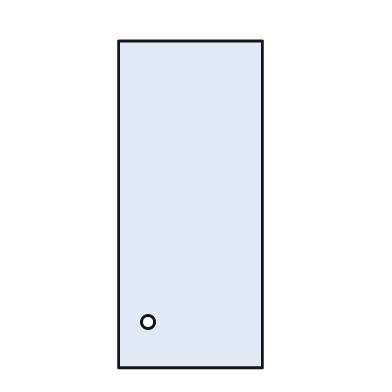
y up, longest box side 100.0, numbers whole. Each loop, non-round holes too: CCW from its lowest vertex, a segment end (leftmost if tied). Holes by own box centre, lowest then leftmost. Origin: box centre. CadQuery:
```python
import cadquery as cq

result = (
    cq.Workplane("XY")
    .moveTo(-22.0, -50.0)
    .lineTo(22.0, -50.0)
    .lineTo(22.0, 50.0)
    .lineTo(-22.0, 50.0)
    .close()
    .moveTo(-13.0, -36.0)
    .circle(2.0)
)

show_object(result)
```